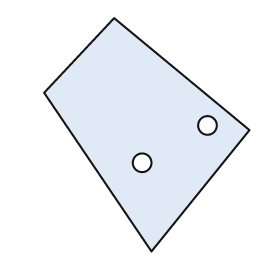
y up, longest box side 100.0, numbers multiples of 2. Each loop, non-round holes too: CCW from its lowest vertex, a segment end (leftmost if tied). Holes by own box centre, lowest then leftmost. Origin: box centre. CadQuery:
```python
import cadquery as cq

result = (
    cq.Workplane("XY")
    .moveTo(2.0, -50.0)
    .lineTo(44.0, 2.0)
    .lineTo(-14.0, 50.0)
    .lineTo(-44.0, 18.0)
    .close()
    .moveTo(-2.0, -12.0)
    .circle(4.0)
    .moveTo(26.0, 4.0)
    .circle(4.0)
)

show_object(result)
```